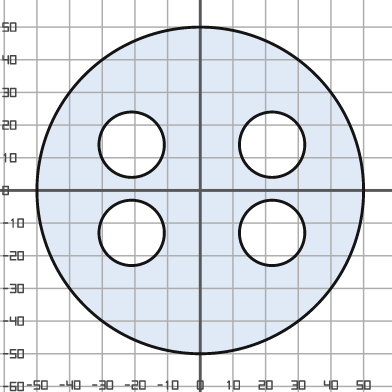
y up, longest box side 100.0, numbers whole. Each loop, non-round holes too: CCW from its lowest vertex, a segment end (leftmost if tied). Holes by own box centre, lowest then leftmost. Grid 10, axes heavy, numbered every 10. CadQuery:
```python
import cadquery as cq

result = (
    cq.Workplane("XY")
    .moveTo(0.0, 0.0)
    .circle(50.0)
    .moveTo(-21.0, -13.0)
    .circle(10.0)
    .moveTo(22.0, -13.0)
    .circle(10.0)
    .moveTo(-21.0, 14.0)
    .circle(10.0)
    .moveTo(22.0, 14.0)
    .circle(10.0)
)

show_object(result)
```